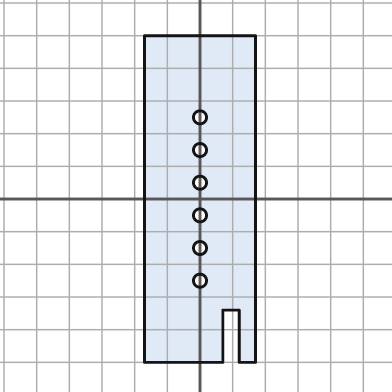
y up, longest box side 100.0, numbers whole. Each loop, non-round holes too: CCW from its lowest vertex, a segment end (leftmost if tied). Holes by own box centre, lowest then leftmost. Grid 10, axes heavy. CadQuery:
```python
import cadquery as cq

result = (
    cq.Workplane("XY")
    .moveTo(-17.0, -50.0)
    .lineTo(7.0, -50.0)
    .lineTo(7.0, -34.0)
    .lineTo(12.0, -34.0)
    .lineTo(12.0, -50.0)
    .lineTo(17.0, -50.0)
    .lineTo(17.0, 50.0)
    .lineTo(-17.0, 50.0)
    .close()
    .moveTo(0.0, -25.0)
    .circle(2.0)
    .moveTo(0.0, -15.0)
    .circle(2.0)
    .moveTo(0.0, -5.0)
    .circle(2.0)
    .moveTo(0.0, 5.0)
    .circle(2.0)
    .moveTo(0.0, 15.0)
    .circle(2.0)
    .moveTo(0.0, 25.0)
    .circle(2.0)
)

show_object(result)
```